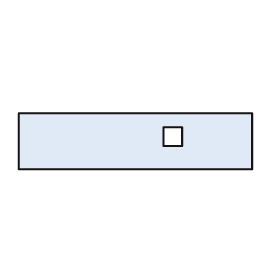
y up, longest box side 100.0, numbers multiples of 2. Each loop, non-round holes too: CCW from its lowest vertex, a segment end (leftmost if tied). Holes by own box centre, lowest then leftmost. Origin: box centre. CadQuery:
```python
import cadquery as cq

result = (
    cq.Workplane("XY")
    .moveTo(-50.0, -12.0)
    .lineTo(50.0, -12.0)
    .lineTo(50.0, 12.0)
    .lineTo(-50.0, 12.0)
    .close()
    .moveTo(12.0, -2.0)
    .lineTo(20.0, -2.0)
    .lineTo(20.0, 6.0)
    .lineTo(12.0, 6.0)
    .close()
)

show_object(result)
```